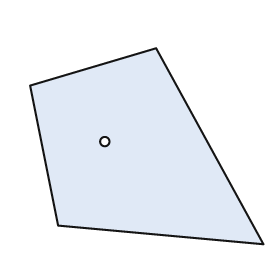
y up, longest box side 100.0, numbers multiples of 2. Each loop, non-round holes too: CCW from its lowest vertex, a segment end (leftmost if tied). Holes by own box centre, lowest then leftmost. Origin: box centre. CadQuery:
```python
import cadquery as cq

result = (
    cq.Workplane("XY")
    .moveTo(50.0, -42.0)
    .lineTo(4.0, 42.0)
    .lineTo(-50.0, 26.0)
    .lineTo(-38.0, -34.0)
    .close()
    .moveTo(-18.0, 2.0)
    .circle(2.0)
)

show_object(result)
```